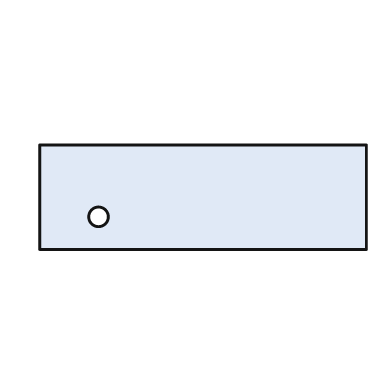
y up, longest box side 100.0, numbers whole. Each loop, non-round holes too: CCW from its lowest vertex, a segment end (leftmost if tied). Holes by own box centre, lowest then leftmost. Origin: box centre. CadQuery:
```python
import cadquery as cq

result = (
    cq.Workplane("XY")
    .moveTo(-50.0, -16.0)
    .lineTo(50.0, -16.0)
    .lineTo(50.0, 16.0)
    .lineTo(-50.0, 16.0)
    .close()
    .moveTo(-32.0, -6.0)
    .circle(3.0)
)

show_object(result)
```